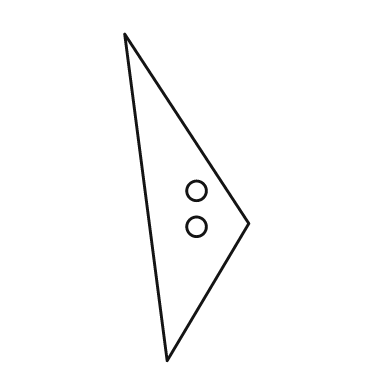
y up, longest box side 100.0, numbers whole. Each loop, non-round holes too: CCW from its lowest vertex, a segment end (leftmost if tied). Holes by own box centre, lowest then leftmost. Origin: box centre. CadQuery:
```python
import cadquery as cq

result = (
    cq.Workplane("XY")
    .moveTo(-6.0, -50.0)
    .lineTo(19.0, -8.0)
    .lineTo(-19.0, 50.0)
    .close()
    .moveTo(3.0, -9.0)
    .circle(3.0)
    .moveTo(3.0, 2.0)
    .circle(3.0)
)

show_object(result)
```